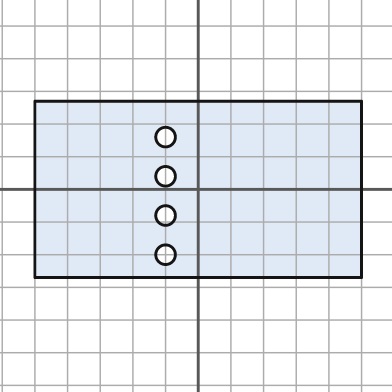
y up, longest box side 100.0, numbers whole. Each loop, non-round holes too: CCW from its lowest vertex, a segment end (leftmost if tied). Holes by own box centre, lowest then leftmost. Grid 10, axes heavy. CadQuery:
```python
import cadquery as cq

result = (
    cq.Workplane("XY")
    .moveTo(-50.0, -27.0)
    .lineTo(50.0, -27.0)
    .lineTo(50.0, 27.0)
    .lineTo(-50.0, 27.0)
    .close()
    .moveTo(-10.0, -20.0)
    .circle(3.0)
    .moveTo(-10.0, -8.0)
    .circle(3.0)
    .moveTo(-10.0, 4.0)
    .circle(3.0)
    .moveTo(-10.0, 16.0)
    .circle(3.0)
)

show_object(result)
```